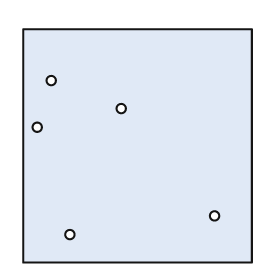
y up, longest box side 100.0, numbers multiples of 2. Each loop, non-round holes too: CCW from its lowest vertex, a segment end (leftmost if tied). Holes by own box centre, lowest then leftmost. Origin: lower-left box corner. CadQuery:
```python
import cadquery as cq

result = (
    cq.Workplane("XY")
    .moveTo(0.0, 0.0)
    .lineTo(98.0, 0.0)
    .lineTo(98.0, 100.0)
    .lineTo(0.0, 100.0)
    .close()
    .moveTo(20.0, 12.0)
    .circle(2.0)
    .moveTo(82.0, 20.0)
    .circle(2.0)
    .moveTo(6.0, 58.0)
    .circle(2.0)
    .moveTo(42.0, 66.0)
    .circle(2.0)
    .moveTo(12.0, 78.0)
    .circle(2.0)
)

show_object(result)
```